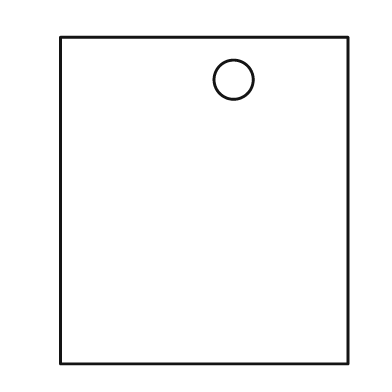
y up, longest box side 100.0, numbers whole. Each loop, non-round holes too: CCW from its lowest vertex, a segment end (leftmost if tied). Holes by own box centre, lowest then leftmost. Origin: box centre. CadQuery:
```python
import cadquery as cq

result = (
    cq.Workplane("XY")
    .moveTo(-44.0, -50.0)
    .lineTo(44.0, -50.0)
    .lineTo(44.0, 50.0)
    .lineTo(-44.0, 50.0)
    .close()
    .moveTo(9.0, 37.0)
    .circle(6.0)
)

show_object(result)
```